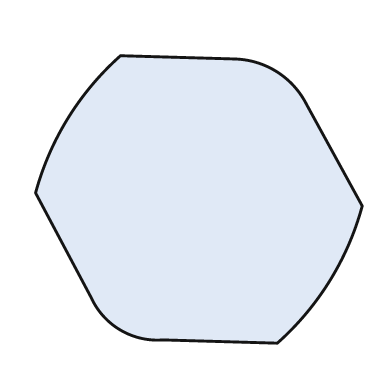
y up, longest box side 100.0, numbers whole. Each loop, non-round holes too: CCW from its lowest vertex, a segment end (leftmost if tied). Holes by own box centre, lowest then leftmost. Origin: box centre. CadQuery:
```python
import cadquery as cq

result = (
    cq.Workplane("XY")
    .moveTo(24.0, -44.0)
    .threePointArc((40.0, -25.0), (50.0, -2.0))
    .lineTo(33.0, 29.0)
    .threePointArc((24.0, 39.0), (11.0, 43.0))
    .lineTo(-24.0, 44.0)
    .threePointArc((-40.0, 25.0), (-50.0, 2.0))
    .lineTo(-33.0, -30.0)
    .threePointArc((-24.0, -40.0), (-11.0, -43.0))
    .close()
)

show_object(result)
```